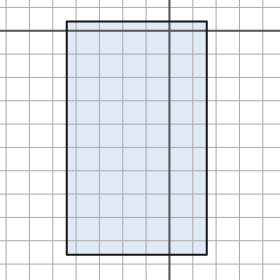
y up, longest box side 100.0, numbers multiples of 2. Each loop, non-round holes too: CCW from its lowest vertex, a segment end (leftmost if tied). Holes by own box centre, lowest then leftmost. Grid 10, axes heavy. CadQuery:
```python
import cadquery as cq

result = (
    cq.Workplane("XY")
    .moveTo(-44.0, -96.0)
    .lineTo(16.0, -96.0)
    .lineTo(16.0, 4.0)
    .lineTo(-44.0, 4.0)
    .close()
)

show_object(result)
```